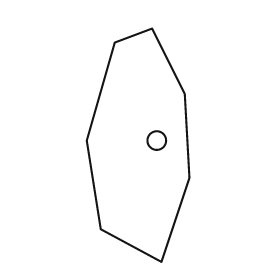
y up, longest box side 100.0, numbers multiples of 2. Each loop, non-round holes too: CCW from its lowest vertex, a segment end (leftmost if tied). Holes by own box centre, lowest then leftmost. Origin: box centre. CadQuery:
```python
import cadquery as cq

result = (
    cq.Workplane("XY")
    .moveTo(10.0, -50.0)
    .lineTo(22.0, -14.0)
    .lineTo(20.0, 22.0)
    .lineTo(6.0, 50.0)
    .lineTo(-10.0, 44.0)
    .lineTo(-22.0, 2.0)
    .lineTo(-16.0, -36.0)
    .close()
    .moveTo(8.0, 2.0)
    .circle(4.0)
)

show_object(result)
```